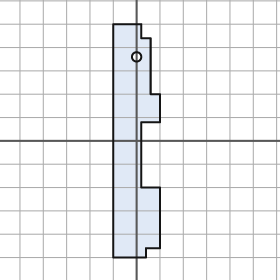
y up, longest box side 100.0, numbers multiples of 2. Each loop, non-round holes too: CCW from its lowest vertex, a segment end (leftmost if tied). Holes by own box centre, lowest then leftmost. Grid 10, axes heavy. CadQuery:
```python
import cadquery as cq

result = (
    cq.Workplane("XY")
    .moveTo(-10.0, -50.0)
    .lineTo(4.0, -50.0)
    .lineTo(4.0, -46.0)
    .lineTo(10.0, -46.0)
    .lineTo(10.0, -20.0)
    .lineTo(2.0, -20.0)
    .lineTo(2.0, 8.0)
    .lineTo(10.0, 8.0)
    .lineTo(10.0, 20.0)
    .lineTo(6.0, 20.0)
    .lineTo(6.0, 44.0)
    .lineTo(2.0, 44.0)
    .lineTo(2.0, 50.0)
    .lineTo(-10.0, 50.0)
    .close()
    .moveTo(0.0, 36.0)
    .circle(2.0)
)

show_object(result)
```